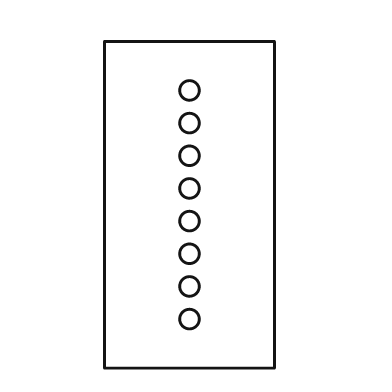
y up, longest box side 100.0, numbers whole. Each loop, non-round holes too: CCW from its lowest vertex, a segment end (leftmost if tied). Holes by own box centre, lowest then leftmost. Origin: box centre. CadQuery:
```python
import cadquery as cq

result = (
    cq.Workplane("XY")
    .moveTo(-26.0, -50.0)
    .lineTo(26.0, -50.0)
    .lineTo(26.0, 50.0)
    .lineTo(-26.0, 50.0)
    .close()
    .moveTo(0.0, -35.0)
    .circle(3.0)
    .moveTo(0.0, -25.0)
    .circle(3.0)
    .moveTo(0.0, -15.0)
    .circle(3.0)
    .moveTo(0.0, -5.0)
    .circle(3.0)
    .moveTo(0.0, 5.0)
    .circle(3.0)
    .moveTo(0.0, 15.0)
    .circle(3.0)
    .moveTo(0.0, 25.0)
    .circle(3.0)
    .moveTo(0.0, 35.0)
    .circle(3.0)
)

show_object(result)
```